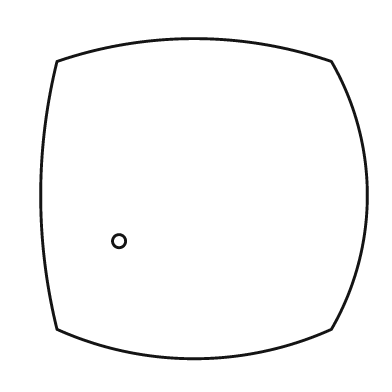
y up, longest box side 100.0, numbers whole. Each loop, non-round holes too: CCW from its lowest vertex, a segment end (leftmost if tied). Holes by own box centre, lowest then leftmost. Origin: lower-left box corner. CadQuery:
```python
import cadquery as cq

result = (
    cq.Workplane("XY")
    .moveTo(5.0, 9.0)
    .threePointArc((47.0, 0.0), (89.0, 9.0))
    .threePointArc((100.0, 50.0), (89.0, 91.0))
    .threePointArc((47.0, 98.0), (5.0, 91.0))
    .threePointArc((0.0, 50.0), (5.0, 9.0))
    .close()
    .moveTo(24.0, 36.0)
    .circle(2.0)
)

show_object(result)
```